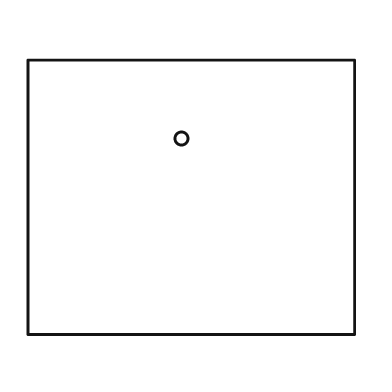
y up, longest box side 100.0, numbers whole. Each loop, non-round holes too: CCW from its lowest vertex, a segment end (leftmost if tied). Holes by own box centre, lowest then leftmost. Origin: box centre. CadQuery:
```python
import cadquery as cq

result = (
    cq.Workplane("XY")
    .moveTo(-50.0, -42.0)
    .lineTo(50.0, -42.0)
    .lineTo(50.0, 42.0)
    .lineTo(-50.0, 42.0)
    .close()
    .moveTo(-3.0, 18.0)
    .circle(2.0)
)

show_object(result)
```